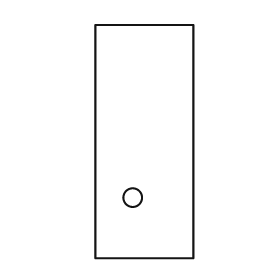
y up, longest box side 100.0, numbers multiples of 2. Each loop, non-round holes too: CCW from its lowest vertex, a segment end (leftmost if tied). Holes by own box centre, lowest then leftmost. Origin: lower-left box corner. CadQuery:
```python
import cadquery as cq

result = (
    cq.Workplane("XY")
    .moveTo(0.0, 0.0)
    .lineTo(42.0, 0.0)
    .lineTo(42.0, 100.0)
    .lineTo(0.0, 100.0)
    .close()
    .moveTo(16.0, 26.0)
    .circle(4.0)
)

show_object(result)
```